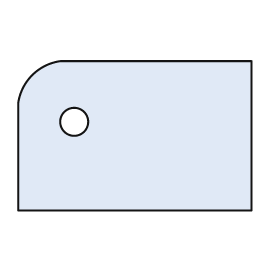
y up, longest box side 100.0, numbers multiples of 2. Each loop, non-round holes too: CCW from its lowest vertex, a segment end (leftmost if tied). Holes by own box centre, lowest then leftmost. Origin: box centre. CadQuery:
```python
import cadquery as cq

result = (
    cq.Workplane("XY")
    .moveTo(-50.0, -32.0)
    .lineTo(50.0, -32.0)
    .lineTo(50.0, 32.0)
    .lineTo(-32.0, 32.0)
    .threePointArc((-44.0, 26.0), (-50.0, 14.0))
    .close()
    .moveTo(-26.0, 6.0)
    .circle(6.0)
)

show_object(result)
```